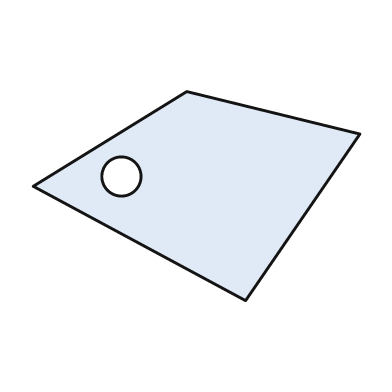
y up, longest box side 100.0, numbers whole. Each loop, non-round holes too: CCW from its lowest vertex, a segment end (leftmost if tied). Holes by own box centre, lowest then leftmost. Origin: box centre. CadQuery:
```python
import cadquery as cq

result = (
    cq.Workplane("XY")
    .moveTo(15.0, -32.0)
    .lineTo(50.0, 19.0)
    .lineTo(-3.0, 32.0)
    .lineTo(-50.0, 3.0)
    .close()
    .moveTo(-23.0, 6.0)
    .circle(6.0)
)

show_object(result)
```